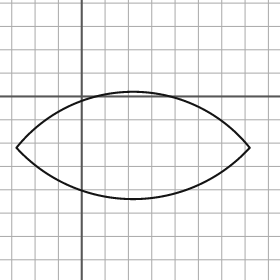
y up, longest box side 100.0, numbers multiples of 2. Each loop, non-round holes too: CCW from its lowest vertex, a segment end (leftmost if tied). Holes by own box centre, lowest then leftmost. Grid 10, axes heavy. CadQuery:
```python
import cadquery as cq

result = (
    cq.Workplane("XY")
    .moveTo(-28.0, -22.0)
    .threePointArc((22.0, -44.0), (72.0, -22.0))
    .threePointArc((22.0, 2.0), (-28.0, -22.0))
    .close()
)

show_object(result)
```